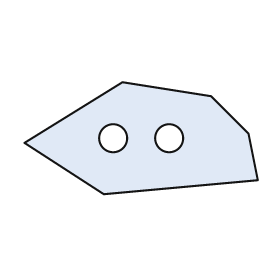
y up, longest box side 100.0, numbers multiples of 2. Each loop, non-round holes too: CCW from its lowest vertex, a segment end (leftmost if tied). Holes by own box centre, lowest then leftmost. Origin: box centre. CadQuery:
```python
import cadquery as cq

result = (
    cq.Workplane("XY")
    .moveTo(-16.0, -24.0)
    .lineTo(50.0, -18.0)
    .lineTo(46.0, 2.0)
    .lineTo(30.0, 18.0)
    .lineTo(-8.0, 24.0)
    .lineTo(-50.0, -2.0)
    .close()
    .moveTo(-12.0, 0.0)
    .circle(6.0)
    .moveTo(12.0, 0.0)
    .circle(6.0)
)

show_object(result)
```